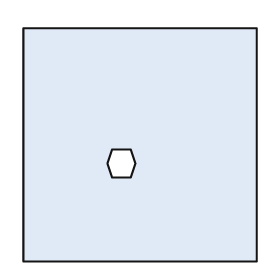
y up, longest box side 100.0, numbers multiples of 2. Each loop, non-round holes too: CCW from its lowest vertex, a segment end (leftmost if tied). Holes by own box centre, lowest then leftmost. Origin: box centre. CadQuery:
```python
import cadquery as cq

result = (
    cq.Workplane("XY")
    .moveTo(-50.0, -50.0)
    .lineTo(50.0, -50.0)
    .lineTo(50.0, 50.0)
    .lineTo(-50.0, 50.0)
    .close()
    .moveTo(-12.0, -14.0)
    .lineTo(-4.0, -14.0)
    .lineTo(-2.0, -8.0)
    .lineTo(-4.0, -2.0)
    .lineTo(-12.0, -2.0)
    .lineTo(-14.0, -8.0)
    .close()
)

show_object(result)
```